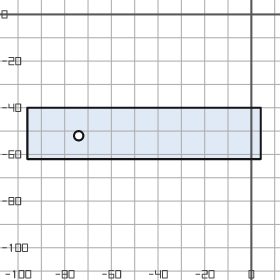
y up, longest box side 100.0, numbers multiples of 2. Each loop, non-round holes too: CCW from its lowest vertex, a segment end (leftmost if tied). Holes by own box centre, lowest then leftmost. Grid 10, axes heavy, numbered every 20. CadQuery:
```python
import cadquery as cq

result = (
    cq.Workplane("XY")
    .moveTo(-96.0, -62.0)
    .lineTo(4.0, -62.0)
    .lineTo(4.0, -40.0)
    .lineTo(-96.0, -40.0)
    .close()
    .moveTo(-74.0, -52.0)
    .circle(2.0)
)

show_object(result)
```